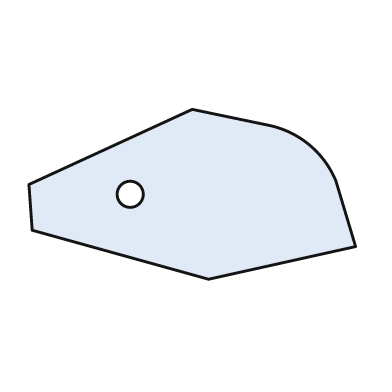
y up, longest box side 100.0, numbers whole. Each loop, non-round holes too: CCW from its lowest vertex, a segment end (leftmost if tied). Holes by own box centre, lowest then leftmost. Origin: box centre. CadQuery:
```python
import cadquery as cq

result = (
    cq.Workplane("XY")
    .moveTo(5.0, -26.0)
    .lineTo(50.0, -16.0)
    .lineTo(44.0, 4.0)
    .threePointArc((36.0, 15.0), (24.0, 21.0))
    .lineTo(0.0, 26.0)
    .lineTo(-50.0, 3.0)
    .lineTo(-49.0, -11.0)
    .close()
    .moveTo(-19.0, 0.0)
    .circle(4.0)
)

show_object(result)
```